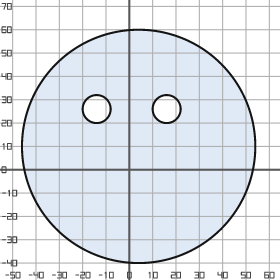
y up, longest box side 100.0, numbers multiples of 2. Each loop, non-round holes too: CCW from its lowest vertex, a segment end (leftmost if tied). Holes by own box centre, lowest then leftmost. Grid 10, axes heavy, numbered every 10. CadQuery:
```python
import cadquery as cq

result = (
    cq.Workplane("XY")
    .moveTo(4.0, 10.0)
    .circle(50.0)
    .moveTo(-14.0, 26.0)
    .circle(6.0)
    .moveTo(16.0, 26.0)
    .circle(6.0)
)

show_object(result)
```